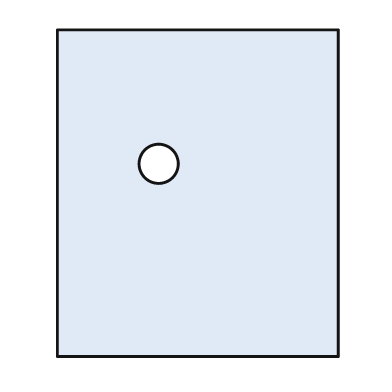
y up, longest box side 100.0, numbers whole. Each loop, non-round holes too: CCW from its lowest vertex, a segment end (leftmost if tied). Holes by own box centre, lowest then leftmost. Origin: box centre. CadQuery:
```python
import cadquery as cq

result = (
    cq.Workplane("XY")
    .moveTo(-43.0, -50.0)
    .lineTo(43.0, -50.0)
    .lineTo(43.0, 50.0)
    .lineTo(-43.0, 50.0)
    .close()
    .moveTo(-12.0, 9.0)
    .circle(6.0)
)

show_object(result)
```